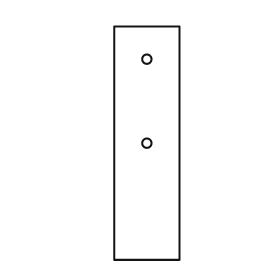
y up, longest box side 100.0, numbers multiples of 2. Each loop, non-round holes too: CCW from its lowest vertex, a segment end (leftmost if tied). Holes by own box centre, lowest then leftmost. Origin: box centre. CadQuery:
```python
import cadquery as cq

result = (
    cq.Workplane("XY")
    .moveTo(-14.0, -50.0)
    .lineTo(14.0, -50.0)
    .lineTo(14.0, 50.0)
    .lineTo(-14.0, 50.0)
    .close()
    .moveTo(0.0, 0.0)
    .circle(2.0)
    .moveTo(0.0, 36.0)
    .circle(2.0)
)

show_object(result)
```